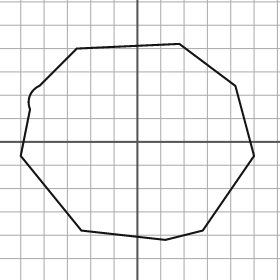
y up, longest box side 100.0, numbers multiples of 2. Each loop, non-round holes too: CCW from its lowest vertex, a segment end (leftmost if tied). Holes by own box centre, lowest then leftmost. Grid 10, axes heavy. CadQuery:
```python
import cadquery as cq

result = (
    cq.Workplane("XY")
    .moveTo(12.0, -42.0)
    .lineTo(28.0, -38.0)
    .lineTo(50.0, -6.0)
    .lineTo(42.0, 24.0)
    .lineTo(18.0, 42.0)
    .lineTo(-26.0, 40.0)
    .lineTo(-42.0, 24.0)
    .threePointArc((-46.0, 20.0), (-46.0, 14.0))
    .lineTo(-50.0, -6.0)
    .lineTo(-24.0, -38.0)
    .close()
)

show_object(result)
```